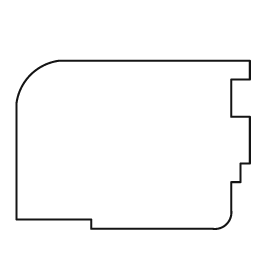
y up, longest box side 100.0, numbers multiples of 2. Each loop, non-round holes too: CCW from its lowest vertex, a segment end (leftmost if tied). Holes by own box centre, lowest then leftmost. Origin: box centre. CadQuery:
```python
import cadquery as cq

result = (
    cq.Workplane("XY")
    .moveTo(-18.0, -36.0)
    .lineTo(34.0, -36.0)
    .threePointArc((40.0, -34.0), (42.0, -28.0))
    .lineTo(42.0, -16.0)
    .lineTo(46.0, -16.0)
    .lineTo(46.0, -8.0)
    .lineTo(50.0, -8.0)
    .lineTo(50.0, 12.0)
    .lineTo(42.0, 12.0)
    .lineTo(42.0, 28.0)
    .lineTo(50.0, 28.0)
    .lineTo(50.0, 36.0)
    .lineTo(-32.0, 36.0)
    .threePointArc((-44.0, 30.0), (-50.0, 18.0))
    .lineTo(-50.0, -32.0)
    .lineTo(-18.0, -32.0)
    .close()
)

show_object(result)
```